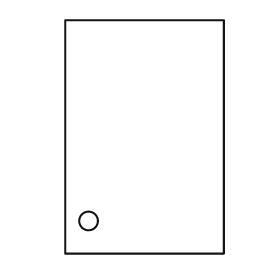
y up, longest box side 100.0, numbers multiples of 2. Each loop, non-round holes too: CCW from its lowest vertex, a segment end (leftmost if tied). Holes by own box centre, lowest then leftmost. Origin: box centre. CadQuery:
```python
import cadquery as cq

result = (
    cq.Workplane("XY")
    .moveTo(-34.0, -50.0)
    .lineTo(34.0, -50.0)
    .lineTo(34.0, 50.0)
    .lineTo(-34.0, 50.0)
    .close()
    .moveTo(-24.0, -36.0)
    .circle(4.0)
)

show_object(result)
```